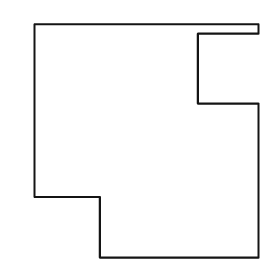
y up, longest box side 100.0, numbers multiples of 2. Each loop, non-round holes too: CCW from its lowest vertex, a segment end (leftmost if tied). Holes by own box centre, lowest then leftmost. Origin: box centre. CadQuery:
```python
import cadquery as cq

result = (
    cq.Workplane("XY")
    .moveTo(-20.0, -50.0)
    .lineTo(48.0, -50.0)
    .lineTo(48.0, 16.0)
    .lineTo(22.0, 16.0)
    .lineTo(22.0, 46.0)
    .lineTo(48.0, 46.0)
    .lineTo(48.0, 50.0)
    .lineTo(-48.0, 50.0)
    .lineTo(-48.0, -24.0)
    .lineTo(-20.0, -24.0)
    .close()
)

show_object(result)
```